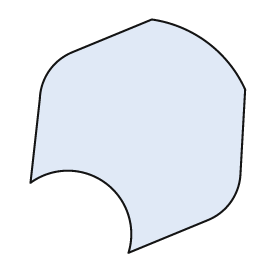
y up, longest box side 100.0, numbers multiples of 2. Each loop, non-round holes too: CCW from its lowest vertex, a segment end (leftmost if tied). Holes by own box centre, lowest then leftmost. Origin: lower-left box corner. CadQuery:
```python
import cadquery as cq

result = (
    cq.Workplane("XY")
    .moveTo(42.0, 0.0)
    .lineTo(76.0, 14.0)
    .threePointArc((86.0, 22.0), (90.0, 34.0))
    .lineTo(92.0, 70.0)
    .threePointArc((76.0, 90.0), (52.0, 100.0))
    .lineTo(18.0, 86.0)
    .threePointArc((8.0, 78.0), (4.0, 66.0))
    .lineTo(0.0, 30.0)
    .threePointArc((32.0, 30.0), (42.0, 0.0))
    .close()
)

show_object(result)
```